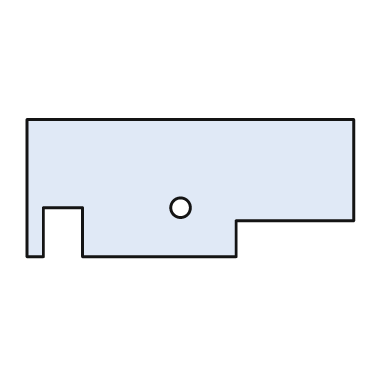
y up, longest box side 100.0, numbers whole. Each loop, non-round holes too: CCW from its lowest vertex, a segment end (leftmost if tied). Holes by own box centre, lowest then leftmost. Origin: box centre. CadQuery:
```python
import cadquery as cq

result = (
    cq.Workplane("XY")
    .moveTo(-50.0, -21.0)
    .lineTo(-45.0, -21.0)
    .lineTo(-45.0, -6.0)
    .lineTo(-33.0, -6.0)
    .lineTo(-33.0, -21.0)
    .lineTo(14.0, -21.0)
    .lineTo(14.0, -10.0)
    .lineTo(50.0, -10.0)
    .lineTo(50.0, 21.0)
    .lineTo(-50.0, 21.0)
    .close()
    .moveTo(-3.0, -6.0)
    .circle(3.0)
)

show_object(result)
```